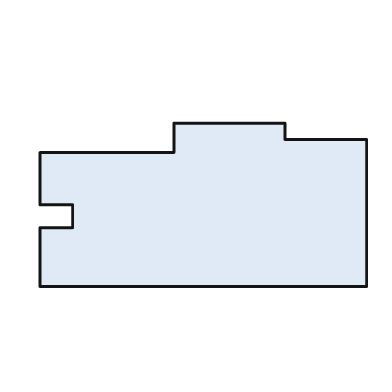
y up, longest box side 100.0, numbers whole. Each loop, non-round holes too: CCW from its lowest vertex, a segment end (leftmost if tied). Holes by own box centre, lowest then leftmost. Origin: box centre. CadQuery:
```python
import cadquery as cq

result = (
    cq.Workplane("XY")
    .moveTo(-50.0, -25.0)
    .lineTo(50.0, -25.0)
    .lineTo(50.0, 20.0)
    .lineTo(25.0, 20.0)
    .lineTo(25.0, 25.0)
    .lineTo(-9.0, 25.0)
    .lineTo(-9.0, 16.0)
    .lineTo(-50.0, 16.0)
    .lineTo(-50.0, 0.0)
    .lineTo(-40.0, 0.0)
    .lineTo(-40.0, -7.0)
    .lineTo(-50.0, -7.0)
    .close()
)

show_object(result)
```